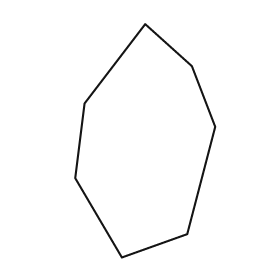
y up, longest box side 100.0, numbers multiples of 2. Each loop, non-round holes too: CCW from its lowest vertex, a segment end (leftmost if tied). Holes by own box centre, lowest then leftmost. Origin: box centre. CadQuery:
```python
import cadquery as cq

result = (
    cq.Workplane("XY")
    .moveTo(-10.0, -50.0)
    .lineTo(18.0, -40.0)
    .lineTo(30.0, 6.0)
    .lineTo(20.0, 32.0)
    .lineTo(0.0, 50.0)
    .lineTo(-26.0, 16.0)
    .lineTo(-30.0, -16.0)
    .close()
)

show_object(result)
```